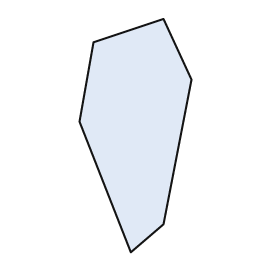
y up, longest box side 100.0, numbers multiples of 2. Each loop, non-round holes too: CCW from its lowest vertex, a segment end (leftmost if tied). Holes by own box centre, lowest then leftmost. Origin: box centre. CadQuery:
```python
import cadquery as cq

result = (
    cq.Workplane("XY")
    .moveTo(-2.0, -50.0)
    .lineTo(12.0, -38.0)
    .lineTo(24.0, 24.0)
    .lineTo(12.0, 50.0)
    .lineTo(-18.0, 40.0)
    .lineTo(-24.0, 6.0)
    .close()
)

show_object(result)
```